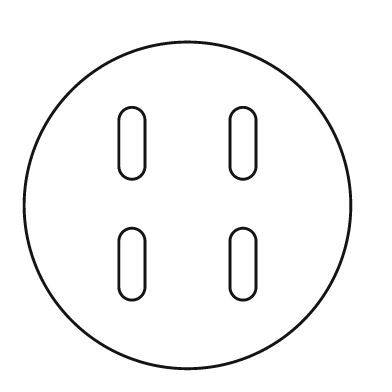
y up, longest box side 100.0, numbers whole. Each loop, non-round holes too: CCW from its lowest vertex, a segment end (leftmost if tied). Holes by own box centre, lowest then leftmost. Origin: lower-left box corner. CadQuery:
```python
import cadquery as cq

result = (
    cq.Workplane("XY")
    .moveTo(50.0, 50.0)
    .circle(50.0)
    .moveTo(29.0, 25.0)
    .threePointArc((33.0, 21.0), (37.0, 25.0))
    .lineTo(37.0, 39.0)
    .threePointArc((33.0, 43.0), (29.0, 39.0))
    .close()
    .moveTo(63.0, 25.0)
    .threePointArc((67.0, 21.0), (71.0, 25.0))
    .lineTo(71.0, 39.0)
    .threePointArc((67.0, 43.0), (63.0, 39.0))
    .close()
    .moveTo(29.0, 62.0)
    .threePointArc((33.0, 58.0), (37.0, 62.0))
    .lineTo(37.0, 76.0)
    .threePointArc((33.0, 80.0), (29.0, 76.0))
    .close()
    .moveTo(63.0, 62.0)
    .threePointArc((67.0, 58.0), (71.0, 62.0))
    .lineTo(71.0, 76.0)
    .threePointArc((67.0, 80.0), (63.0, 76.0))
    .close()
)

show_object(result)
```